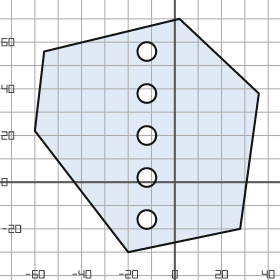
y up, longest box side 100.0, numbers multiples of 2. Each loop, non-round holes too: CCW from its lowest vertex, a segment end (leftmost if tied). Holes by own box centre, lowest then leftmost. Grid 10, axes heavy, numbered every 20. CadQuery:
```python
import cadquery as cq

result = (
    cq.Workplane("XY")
    .moveTo(-20.0, -30.0)
    .lineTo(28.0, -20.0)
    .lineTo(36.0, 38.0)
    .lineTo(2.0, 70.0)
    .lineTo(-56.0, 56.0)
    .lineTo(-60.0, 22.0)
    .close()
    .moveTo(-12.0, -16.0)
    .circle(4.0)
    .moveTo(-12.0, 2.0)
    .circle(4.0)
    .moveTo(-12.0, 20.0)
    .circle(4.0)
    .moveTo(-12.0, 38.0)
    .circle(4.0)
    .moveTo(-12.0, 56.0)
    .circle(4.0)
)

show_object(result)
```